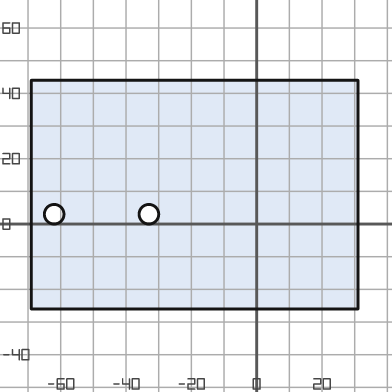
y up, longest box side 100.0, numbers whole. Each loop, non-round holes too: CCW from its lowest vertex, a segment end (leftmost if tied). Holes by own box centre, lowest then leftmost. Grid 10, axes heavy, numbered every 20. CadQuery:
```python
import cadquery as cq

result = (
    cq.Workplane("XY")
    .moveTo(-69.0, -26.0)
    .lineTo(31.0, -26.0)
    .lineTo(31.0, 44.0)
    .lineTo(-69.0, 44.0)
    .close()
    .moveTo(-62.0, 3.0)
    .circle(3.0)
    .moveTo(-33.0, 3.0)
    .circle(3.0)
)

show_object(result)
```